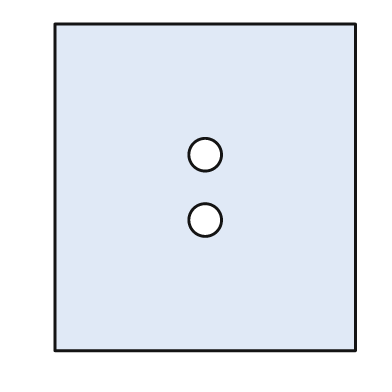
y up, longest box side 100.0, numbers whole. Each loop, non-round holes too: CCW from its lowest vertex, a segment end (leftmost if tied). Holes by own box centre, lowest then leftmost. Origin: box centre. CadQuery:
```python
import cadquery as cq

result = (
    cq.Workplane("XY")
    .moveTo(-46.0, -50.0)
    .lineTo(46.0, -50.0)
    .lineTo(46.0, 50.0)
    .lineTo(-46.0, 50.0)
    .close()
    .moveTo(0.0, -10.0)
    .circle(5.0)
    .moveTo(0.0, 10.0)
    .circle(5.0)
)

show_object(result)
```